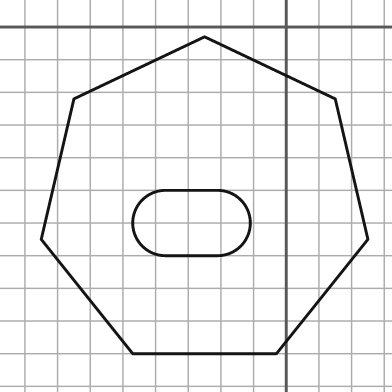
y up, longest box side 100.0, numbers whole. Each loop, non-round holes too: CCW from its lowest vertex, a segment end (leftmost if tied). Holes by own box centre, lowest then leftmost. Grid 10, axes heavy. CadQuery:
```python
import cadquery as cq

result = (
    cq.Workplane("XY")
    .moveTo(-47.0, -100.0)
    .lineTo(-3.0, -100.0)
    .lineTo(25.0, -65.0)
    .lineTo(15.0, -22.0)
    .lineTo(-25.0, -3.0)
    .lineTo(-65.0, -22.0)
    .lineTo(-75.0, -65.0)
    .close()
    .moveTo(-37.0, -70.0)
    .lineTo(-21.0, -70.0)
    .threePointArc((-11.0, -60.0), (-21.0, -50.0))
    .lineTo(-37.0, -50.0)
    .threePointArc((-47.0, -60.0), (-37.0, -70.0))
    .close()
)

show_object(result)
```